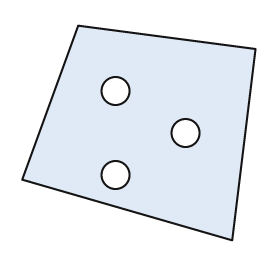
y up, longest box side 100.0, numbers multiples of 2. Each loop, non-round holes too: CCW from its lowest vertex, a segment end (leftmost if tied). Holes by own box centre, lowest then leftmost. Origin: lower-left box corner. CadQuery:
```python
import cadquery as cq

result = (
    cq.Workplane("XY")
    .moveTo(90.0, 0.0)
    .lineTo(100.0, 82.0)
    .lineTo(24.0, 92.0)
    .lineTo(0.0, 26.0)
    .close()
    .moveTo(40.0, 28.0)
    .circle(6.0)
    .moveTo(70.0, 46.0)
    .circle(6.0)
    .moveTo(40.0, 64.0)
    .circle(6.0)
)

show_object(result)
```